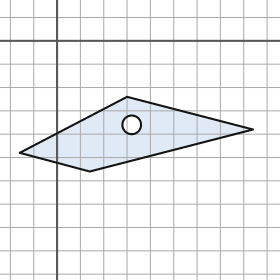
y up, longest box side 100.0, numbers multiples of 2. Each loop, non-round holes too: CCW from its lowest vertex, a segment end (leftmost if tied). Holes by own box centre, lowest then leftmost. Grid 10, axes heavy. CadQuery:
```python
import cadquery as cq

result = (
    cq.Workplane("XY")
    .moveTo(14.0, -56.0)
    .lineTo(84.0, -38.0)
    .lineTo(30.0, -24.0)
    .lineTo(-16.0, -48.0)
    .close()
    .moveTo(32.0, -36.0)
    .circle(4.0)
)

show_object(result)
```